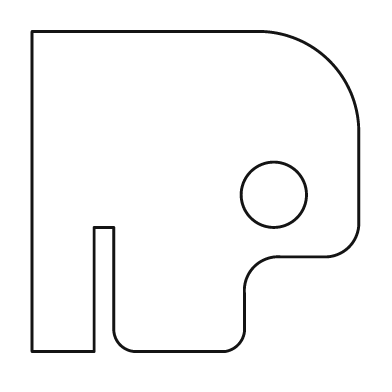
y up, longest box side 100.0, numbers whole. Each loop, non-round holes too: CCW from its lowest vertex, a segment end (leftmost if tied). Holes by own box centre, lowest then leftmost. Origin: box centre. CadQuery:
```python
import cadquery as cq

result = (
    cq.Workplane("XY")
    .moveTo(-50.0, -49.0)
    .lineTo(-31.0, -49.0)
    .lineTo(-31.0, -11.0)
    .lineTo(-25.0, -11.0)
    .lineTo(-25.0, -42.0)
    .threePointArc((-23.0, -47.0), (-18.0, -49.0))
    .lineTo(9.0, -49.0)
    .threePointArc((13.0, -47.0), (15.0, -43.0))
    .lineTo(15.0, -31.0)
    .threePointArc((18.0, -23.0), (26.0, -20.0))
    .lineTo(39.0, -20.0)
    .threePointArc((47.0, -17.0), (50.0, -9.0))
    .lineTo(50.0, 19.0)
    .threePointArc((41.0, 40.0), (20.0, 49.0))
    .lineTo(-50.0, 49.0)
    .close()
    .moveTo(24.0, -1.0)
    .circle(10.0)
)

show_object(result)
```